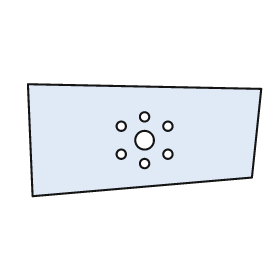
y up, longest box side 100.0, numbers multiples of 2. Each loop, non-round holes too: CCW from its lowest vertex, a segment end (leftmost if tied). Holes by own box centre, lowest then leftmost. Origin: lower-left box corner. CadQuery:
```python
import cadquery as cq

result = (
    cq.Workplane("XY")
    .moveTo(2.0, 0.0)
    .lineTo(96.0, 8.0)
    .lineTo(100.0, 46.0)
    .lineTo(0.0, 48.0)
    .close()
    .moveTo(50.0, 14.0)
    .circle(2.0)
    .moveTo(40.0, 18.0)
    .circle(2.0)
    .moveTo(60.0, 18.0)
    .circle(2.0)
    .moveTo(50.0, 24.0)
    .circle(4.0)
    .moveTo(40.0, 30.0)
    .circle(2.0)
    .moveTo(60.0, 30.0)
    .circle(2.0)
    .moveTo(50.0, 34.0)
    .circle(2.0)
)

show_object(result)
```